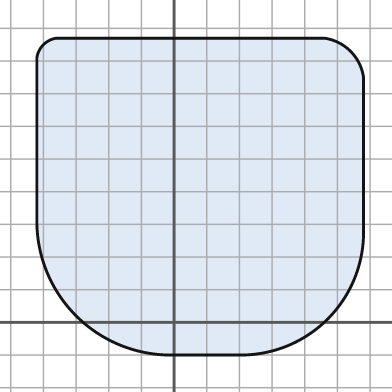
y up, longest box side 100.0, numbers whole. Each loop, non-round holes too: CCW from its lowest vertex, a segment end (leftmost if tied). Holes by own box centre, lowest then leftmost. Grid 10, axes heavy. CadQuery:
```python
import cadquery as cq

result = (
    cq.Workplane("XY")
    .moveTo(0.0, -10.0)
    .lineTo(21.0, -10.0)
    .threePointArc((47.0, 1.0), (58.0, 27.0))
    .lineTo(58.0, 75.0)
    .threePointArc((54.0, 83.0), (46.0, 87.0))
    .lineTo(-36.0, 87.0)
    .threePointArc((-40.0, 85.0), (-42.0, 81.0))
    .lineTo(-42.0, 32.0)
    .threePointArc((-30.0, 2.0), (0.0, -10.0))
    .close()
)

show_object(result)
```